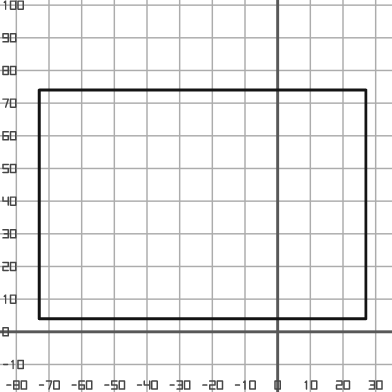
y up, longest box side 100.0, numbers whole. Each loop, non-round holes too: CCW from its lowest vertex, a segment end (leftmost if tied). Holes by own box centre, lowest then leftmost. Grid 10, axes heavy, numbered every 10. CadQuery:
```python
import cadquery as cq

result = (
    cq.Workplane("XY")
    .moveTo(-73.0, 4.0)
    .lineTo(27.0, 4.0)
    .lineTo(27.0, 74.0)
    .lineTo(-73.0, 74.0)
    .close()
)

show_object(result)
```